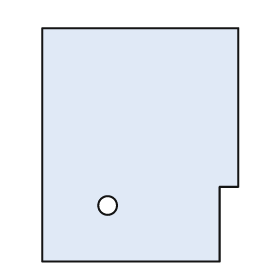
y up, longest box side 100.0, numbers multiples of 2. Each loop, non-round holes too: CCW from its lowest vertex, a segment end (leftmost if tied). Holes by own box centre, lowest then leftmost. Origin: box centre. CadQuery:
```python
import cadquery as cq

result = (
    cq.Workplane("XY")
    .moveTo(-42.0, -50.0)
    .lineTo(34.0, -50.0)
    .lineTo(34.0, -18.0)
    .lineTo(42.0, -18.0)
    .lineTo(42.0, 50.0)
    .lineTo(-42.0, 50.0)
    .close()
    .moveTo(-14.0, -26.0)
    .circle(4.0)
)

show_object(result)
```